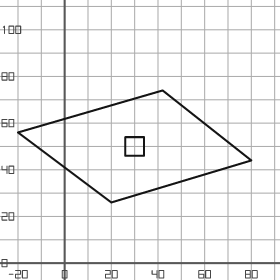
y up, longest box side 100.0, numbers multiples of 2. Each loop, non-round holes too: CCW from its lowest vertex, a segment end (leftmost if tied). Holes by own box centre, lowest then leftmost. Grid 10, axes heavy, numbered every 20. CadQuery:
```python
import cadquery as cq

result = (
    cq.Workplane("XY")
    .moveTo(20.0, 26.0)
    .lineTo(80.0, 44.0)
    .lineTo(42.0, 74.0)
    .lineTo(-20.0, 56.0)
    .close()
    .moveTo(26.0, 46.0)
    .lineTo(34.0, 46.0)
    .lineTo(34.0, 54.0)
    .lineTo(26.0, 54.0)
    .close()
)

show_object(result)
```